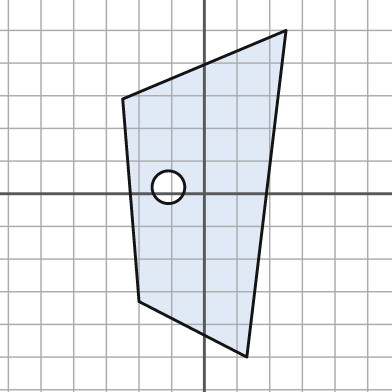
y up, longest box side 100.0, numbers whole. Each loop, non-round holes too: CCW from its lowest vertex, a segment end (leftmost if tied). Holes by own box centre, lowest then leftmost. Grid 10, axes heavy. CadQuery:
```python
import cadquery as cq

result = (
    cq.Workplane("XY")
    .moveTo(13.0, -50.0)
    .lineTo(25.0, 50.0)
    .lineTo(-25.0, 29.0)
    .lineTo(-20.0, -33.0)
    .close()
    .moveTo(-11.0, 2.0)
    .circle(5.0)
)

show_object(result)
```